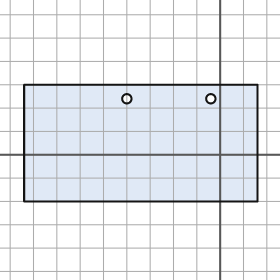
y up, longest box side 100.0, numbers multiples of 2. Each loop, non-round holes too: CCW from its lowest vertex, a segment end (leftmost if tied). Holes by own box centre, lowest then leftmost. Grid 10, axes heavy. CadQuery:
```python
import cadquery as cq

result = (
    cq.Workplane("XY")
    .moveTo(-84.0, -20.0)
    .lineTo(16.0, -20.0)
    .lineTo(16.0, 30.0)
    .lineTo(-84.0, 30.0)
    .close()
    .moveTo(-40.0, 24.0)
    .circle(2.0)
    .moveTo(-4.0, 24.0)
    .circle(2.0)
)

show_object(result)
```